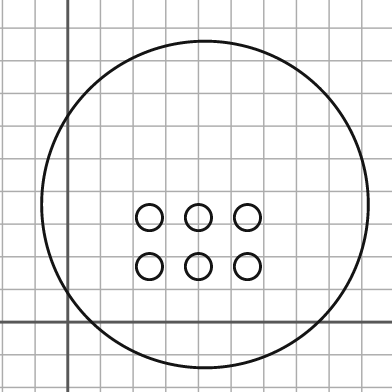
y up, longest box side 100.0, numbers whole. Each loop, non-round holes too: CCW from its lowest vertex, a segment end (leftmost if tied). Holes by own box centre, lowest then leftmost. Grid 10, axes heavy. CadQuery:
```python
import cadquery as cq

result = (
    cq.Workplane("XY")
    .moveTo(42.0, 36.0)
    .circle(50.0)
    .moveTo(25.0, 17.0)
    .circle(4.0)
    .moveTo(40.0, 17.0)
    .circle(4.0)
    .moveTo(55.0, 17.0)
    .circle(4.0)
    .moveTo(25.0, 32.0)
    .circle(4.0)
    .moveTo(40.0, 32.0)
    .circle(4.0)
    .moveTo(55.0, 32.0)
    .circle(4.0)
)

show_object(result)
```